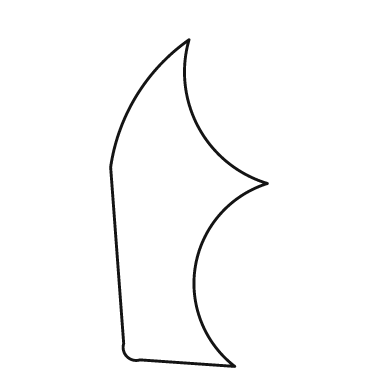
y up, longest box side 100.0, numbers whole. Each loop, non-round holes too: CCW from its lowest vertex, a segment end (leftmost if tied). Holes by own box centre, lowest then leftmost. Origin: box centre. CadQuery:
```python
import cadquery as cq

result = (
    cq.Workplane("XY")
    .moveTo(14.0, -50.0)
    .threePointArc((2.0, -19.0), (24.0, 6.0))
    .threePointArc((3.0, 23.0), (0.0, 50.0))
    .threePointArc((-16.0, 33.0), (-24.0, 11.0))
    .lineTo(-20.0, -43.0)
    .threePointArc((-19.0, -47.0), (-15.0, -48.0))
    .close()
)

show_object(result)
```